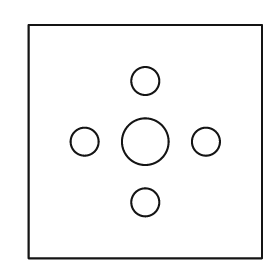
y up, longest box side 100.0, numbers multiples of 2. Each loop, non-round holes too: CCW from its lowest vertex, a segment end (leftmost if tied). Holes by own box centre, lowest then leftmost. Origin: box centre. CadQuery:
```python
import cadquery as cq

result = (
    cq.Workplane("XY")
    .moveTo(-50.0, -50.0)
    .lineTo(50.0, -50.0)
    .lineTo(50.0, 50.0)
    .lineTo(-50.0, 50.0)
    .close()
    .moveTo(0.0, -26.0)
    .circle(6.0)
    .moveTo(-26.0, 0.0)
    .circle(6.0)
    .moveTo(0.0, 0.0)
    .circle(10.0)
    .moveTo(26.0, 0.0)
    .circle(6.0)
    .moveTo(0.0, 26.0)
    .circle(6.0)
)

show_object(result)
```